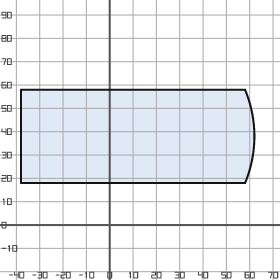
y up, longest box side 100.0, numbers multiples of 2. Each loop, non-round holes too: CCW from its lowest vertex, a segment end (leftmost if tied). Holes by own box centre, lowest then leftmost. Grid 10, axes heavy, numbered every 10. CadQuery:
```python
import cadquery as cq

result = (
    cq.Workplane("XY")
    .moveTo(-38.0, 18.0)
    .lineTo(58.0, 18.0)
    .threePointArc((62.0, 38.0), (58.0, 58.0))
    .lineTo(-38.0, 58.0)
    .close()
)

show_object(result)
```